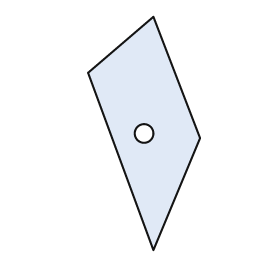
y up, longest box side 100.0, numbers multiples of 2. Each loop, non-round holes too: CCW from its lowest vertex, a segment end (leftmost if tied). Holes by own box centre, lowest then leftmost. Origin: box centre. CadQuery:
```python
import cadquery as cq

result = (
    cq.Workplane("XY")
    .moveTo(4.0, -50.0)
    .lineTo(24.0, -2.0)
    .lineTo(4.0, 50.0)
    .lineTo(-24.0, 26.0)
    .close()
    .moveTo(0.0, 0.0)
    .circle(4.0)
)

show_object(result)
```